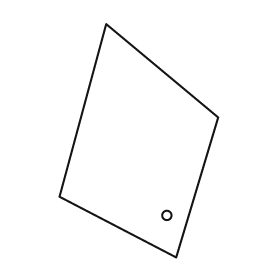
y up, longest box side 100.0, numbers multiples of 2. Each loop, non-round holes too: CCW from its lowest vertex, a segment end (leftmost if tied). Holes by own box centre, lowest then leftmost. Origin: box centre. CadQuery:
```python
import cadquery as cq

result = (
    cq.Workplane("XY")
    .moveTo(16.0, -50.0)
    .lineTo(34.0, 10.0)
    .lineTo(-14.0, 50.0)
    .lineTo(-34.0, -24.0)
    .close()
    .moveTo(12.0, -32.0)
    .circle(2.0)
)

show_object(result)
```